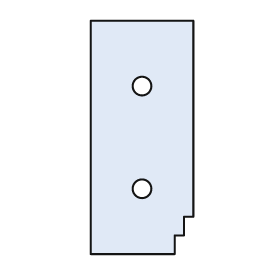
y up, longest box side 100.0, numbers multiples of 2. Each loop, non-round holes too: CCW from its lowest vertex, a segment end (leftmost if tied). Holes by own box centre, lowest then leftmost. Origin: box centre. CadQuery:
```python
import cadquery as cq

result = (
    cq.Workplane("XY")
    .moveTo(-22.0, -50.0)
    .lineTo(14.0, -50.0)
    .lineTo(14.0, -42.0)
    .lineTo(18.0, -42.0)
    .lineTo(18.0, -34.0)
    .lineTo(22.0, -34.0)
    .lineTo(22.0, 50.0)
    .lineTo(-22.0, 50.0)
    .close()
    .moveTo(0.0, -22.0)
    .circle(4.0)
    .moveTo(0.0, 22.0)
    .circle(4.0)
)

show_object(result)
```